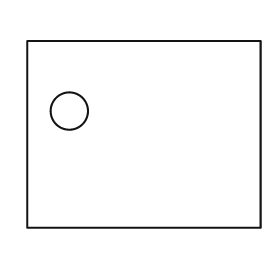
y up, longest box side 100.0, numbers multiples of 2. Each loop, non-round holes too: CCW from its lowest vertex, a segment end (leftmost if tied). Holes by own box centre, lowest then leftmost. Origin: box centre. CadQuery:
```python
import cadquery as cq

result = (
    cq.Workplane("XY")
    .moveTo(-50.0, -40.0)
    .lineTo(50.0, -40.0)
    .lineTo(50.0, 40.0)
    .lineTo(-50.0, 40.0)
    .close()
    .moveTo(-32.0, 10.0)
    .circle(8.0)
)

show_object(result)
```